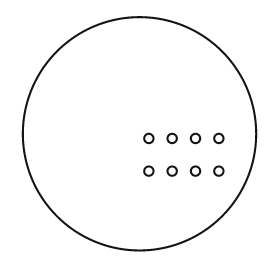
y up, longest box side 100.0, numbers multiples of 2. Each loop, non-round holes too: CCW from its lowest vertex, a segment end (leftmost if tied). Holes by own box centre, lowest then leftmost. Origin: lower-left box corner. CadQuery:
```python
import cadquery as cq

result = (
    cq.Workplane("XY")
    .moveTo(50.0, 50.0)
    .circle(50.0)
    .moveTo(54.0, 34.0)
    .circle(2.0)
    .moveTo(64.0, 34.0)
    .circle(2.0)
    .moveTo(74.0, 34.0)
    .circle(2.0)
    .moveTo(84.0, 34.0)
    .circle(2.0)
    .moveTo(54.0, 48.0)
    .circle(2.0)
    .moveTo(64.0, 48.0)
    .circle(2.0)
    .moveTo(74.0, 48.0)
    .circle(2.0)
    .moveTo(84.0, 48.0)
    .circle(2.0)
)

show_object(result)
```